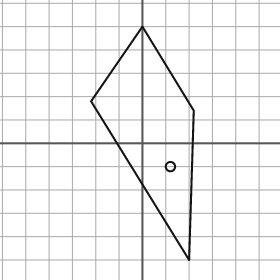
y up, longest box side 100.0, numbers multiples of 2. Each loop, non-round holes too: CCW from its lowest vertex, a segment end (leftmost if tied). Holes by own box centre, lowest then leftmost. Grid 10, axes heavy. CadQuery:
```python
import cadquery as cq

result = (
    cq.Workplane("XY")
    .moveTo(20.0, -50.0)
    .lineTo(22.0, 14.0)
    .lineTo(0.0, 50.0)
    .lineTo(-22.0, 18.0)
    .close()
    .moveTo(12.0, -10.0)
    .circle(2.0)
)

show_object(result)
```